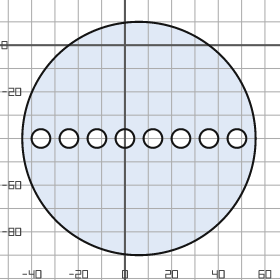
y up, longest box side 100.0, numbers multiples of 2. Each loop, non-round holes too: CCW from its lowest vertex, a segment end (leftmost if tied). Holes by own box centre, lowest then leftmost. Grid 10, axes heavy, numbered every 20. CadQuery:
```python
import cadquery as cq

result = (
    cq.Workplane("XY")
    .moveTo(6.0, -40.0)
    .circle(50.0)
    .moveTo(-36.0, -40.0)
    .circle(4.0)
    .moveTo(-24.0, -40.0)
    .circle(4.0)
    .moveTo(-12.0, -40.0)
    .circle(4.0)
    .moveTo(0.0, -40.0)
    .circle(4.0)
    .moveTo(12.0, -40.0)
    .circle(4.0)
    .moveTo(24.0, -40.0)
    .circle(4.0)
    .moveTo(36.0, -40.0)
    .circle(4.0)
    .moveTo(48.0, -40.0)
    .circle(4.0)
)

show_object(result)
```